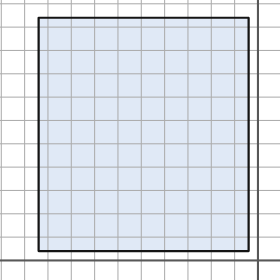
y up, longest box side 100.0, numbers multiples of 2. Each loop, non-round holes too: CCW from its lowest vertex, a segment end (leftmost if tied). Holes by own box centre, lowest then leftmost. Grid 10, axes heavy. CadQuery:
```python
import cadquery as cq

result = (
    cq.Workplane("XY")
    .moveTo(-94.0, 4.0)
    .lineTo(-4.0, 4.0)
    .lineTo(-4.0, 104.0)
    .lineTo(-94.0, 104.0)
    .close()
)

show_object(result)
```